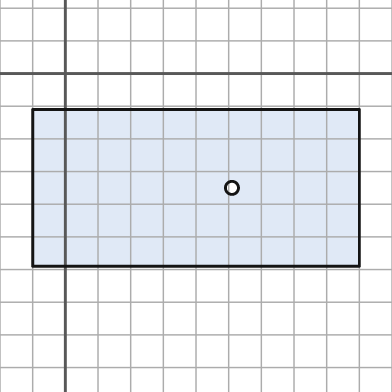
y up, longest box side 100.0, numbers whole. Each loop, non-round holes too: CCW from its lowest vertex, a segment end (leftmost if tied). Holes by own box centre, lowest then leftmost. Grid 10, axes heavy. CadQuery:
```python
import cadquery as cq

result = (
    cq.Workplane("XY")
    .moveTo(-10.0, -59.0)
    .lineTo(90.0, -59.0)
    .lineTo(90.0, -11.0)
    .lineTo(-10.0, -11.0)
    .close()
    .moveTo(51.0, -35.0)
    .circle(2.0)
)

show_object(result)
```